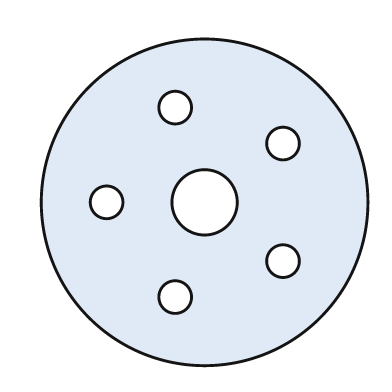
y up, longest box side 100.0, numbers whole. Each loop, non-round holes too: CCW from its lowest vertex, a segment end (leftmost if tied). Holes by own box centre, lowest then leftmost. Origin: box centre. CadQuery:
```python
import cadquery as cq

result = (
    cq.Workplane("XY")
    .moveTo(0.0, 0.0)
    .circle(50.0)
    .moveTo(-9.0, -29.0)
    .circle(5.0)
    .moveTo(24.0, -18.0)
    .circle(5.0)
    .moveTo(-30.0, 0.0)
    .circle(5.0)
    .moveTo(0.0, 0.0)
    .circle(10.0)
    .moveTo(24.0, 18.0)
    .circle(5.0)
    .moveTo(-9.0, 29.0)
    .circle(5.0)
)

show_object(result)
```